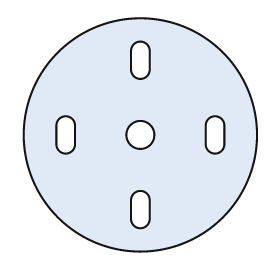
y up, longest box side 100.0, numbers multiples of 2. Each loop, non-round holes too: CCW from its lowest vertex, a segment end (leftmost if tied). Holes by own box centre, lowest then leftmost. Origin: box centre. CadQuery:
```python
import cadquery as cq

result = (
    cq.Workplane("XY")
    .moveTo(0.0, 0.0)
    .circle(50.0)
    .moveTo(-4.0, -36.0)
    .threePointArc((0.0, -40.0), (4.0, -36.0))
    .lineTo(4.0, -28.0)
    .threePointArc((0.0, -24.0), (-4.0, -28.0))
    .close()
    .moveTo(-36.0, -4.0)
    .threePointArc((-32.0, -8.0), (-28.0, -4.0))
    .lineTo(-28.0, 4.0)
    .threePointArc((-32.0, 8.0), (-36.0, 4.0))
    .close()
    .moveTo(0.0, 0.0)
    .circle(6.0)
    .moveTo(28.0, -4.0)
    .threePointArc((32.0, -8.0), (36.0, -4.0))
    .lineTo(36.0, 4.0)
    .threePointArc((32.0, 8.0), (28.0, 4.0))
    .close()
    .moveTo(-4.0, 28.0)
    .threePointArc((0.0, 24.0), (4.0, 28.0))
    .lineTo(4.0, 36.0)
    .threePointArc((0.0, 40.0), (-4.0, 36.0))
    .close()
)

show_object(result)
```